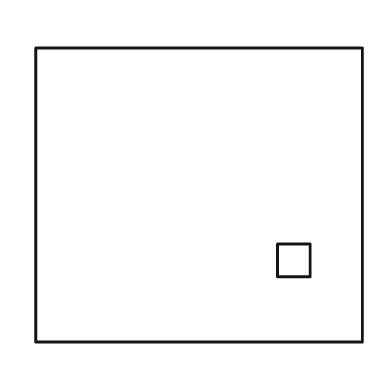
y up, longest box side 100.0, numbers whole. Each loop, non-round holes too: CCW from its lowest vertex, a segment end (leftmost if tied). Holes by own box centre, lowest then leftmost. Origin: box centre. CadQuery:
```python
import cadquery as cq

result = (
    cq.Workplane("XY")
    .moveTo(-50.0, -45.0)
    .lineTo(50.0, -45.0)
    .lineTo(50.0, 45.0)
    .lineTo(-50.0, 45.0)
    .close()
    .moveTo(24.0, -25.0)
    .lineTo(34.0, -25.0)
    .lineTo(34.0, -15.0)
    .lineTo(24.0, -15.0)
    .close()
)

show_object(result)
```